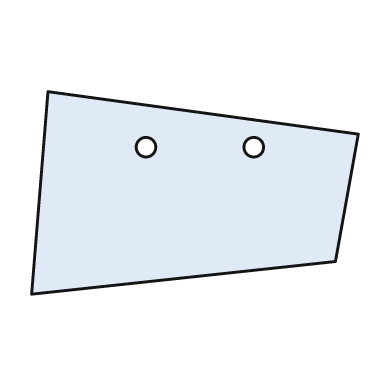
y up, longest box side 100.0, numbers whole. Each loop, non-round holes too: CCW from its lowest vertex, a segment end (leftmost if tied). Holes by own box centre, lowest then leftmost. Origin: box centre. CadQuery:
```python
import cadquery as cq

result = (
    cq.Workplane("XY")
    .moveTo(-50.0, -31.0)
    .lineTo(43.0, -21.0)
    .lineTo(50.0, 18.0)
    .lineTo(-45.0, 31.0)
    .close()
    .moveTo(-15.0, 14.0)
    .circle(3.0)
    .moveTo(18.0, 14.0)
    .circle(3.0)
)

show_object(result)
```